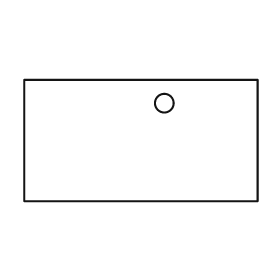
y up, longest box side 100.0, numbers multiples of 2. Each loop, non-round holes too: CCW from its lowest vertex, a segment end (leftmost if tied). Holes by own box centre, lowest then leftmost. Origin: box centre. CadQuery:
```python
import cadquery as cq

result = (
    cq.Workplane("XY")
    .moveTo(-50.0, -26.0)
    .lineTo(50.0, -26.0)
    .lineTo(50.0, 26.0)
    .lineTo(-50.0, 26.0)
    .close()
    .moveTo(10.0, 16.0)
    .circle(4.0)
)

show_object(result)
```